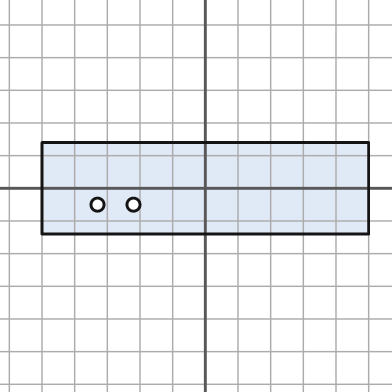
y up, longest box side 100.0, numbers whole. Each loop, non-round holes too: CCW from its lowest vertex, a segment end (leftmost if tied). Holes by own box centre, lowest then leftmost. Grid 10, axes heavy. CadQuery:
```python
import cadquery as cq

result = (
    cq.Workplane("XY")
    .moveTo(-50.0, -14.0)
    .lineTo(50.0, -14.0)
    .lineTo(50.0, 14.0)
    .lineTo(-50.0, 14.0)
    .close()
    .moveTo(-33.0, -5.0)
    .circle(2.0)
    .moveTo(-22.0, -5.0)
    .circle(2.0)
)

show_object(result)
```